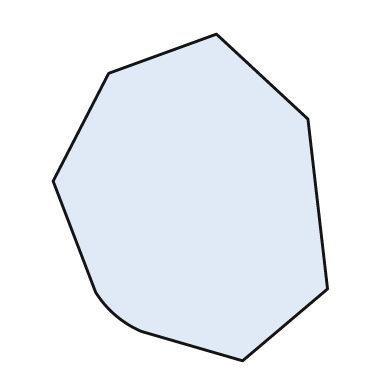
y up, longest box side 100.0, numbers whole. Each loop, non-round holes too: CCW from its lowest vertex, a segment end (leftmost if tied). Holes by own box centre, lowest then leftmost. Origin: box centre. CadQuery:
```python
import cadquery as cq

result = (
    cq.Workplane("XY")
    .moveTo(16.0, -50.0)
    .lineTo(42.0, -28.0)
    .lineTo(36.0, 24.0)
    .lineTo(8.0, 50.0)
    .lineTo(-25.0, 38.0)
    .lineTo(-42.0, 5.0)
    .lineTo(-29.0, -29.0)
    .threePointArc((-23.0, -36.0), (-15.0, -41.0))
    .close()
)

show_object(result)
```